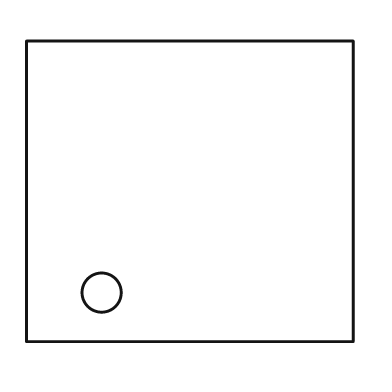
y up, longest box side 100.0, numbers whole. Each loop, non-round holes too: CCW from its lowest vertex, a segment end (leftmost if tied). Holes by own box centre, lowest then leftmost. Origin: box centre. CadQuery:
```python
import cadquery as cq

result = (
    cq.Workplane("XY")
    .moveTo(-50.0, -46.0)
    .lineTo(50.0, -46.0)
    .lineTo(50.0, 46.0)
    .lineTo(-50.0, 46.0)
    .close()
    .moveTo(-27.0, -31.0)
    .circle(6.0)
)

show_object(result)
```